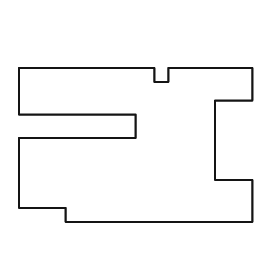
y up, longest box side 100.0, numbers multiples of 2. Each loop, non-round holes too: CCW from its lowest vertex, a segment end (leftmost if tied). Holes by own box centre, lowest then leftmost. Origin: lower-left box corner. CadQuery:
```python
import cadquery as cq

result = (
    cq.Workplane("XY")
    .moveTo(20.0, 0.0)
    .lineTo(100.0, 0.0)
    .lineTo(100.0, 18.0)
    .lineTo(84.0, 18.0)
    .lineTo(84.0, 52.0)
    .lineTo(100.0, 52.0)
    .lineTo(100.0, 66.0)
    .lineTo(64.0, 66.0)
    .lineTo(64.0, 60.0)
    .lineTo(58.0, 60.0)
    .lineTo(58.0, 66.0)
    .lineTo(0.0, 66.0)
    .lineTo(0.0, 46.0)
    .lineTo(50.0, 46.0)
    .lineTo(50.0, 36.0)
    .lineTo(0.0, 36.0)
    .lineTo(0.0, 6.0)
    .lineTo(20.0, 6.0)
    .close()
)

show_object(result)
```